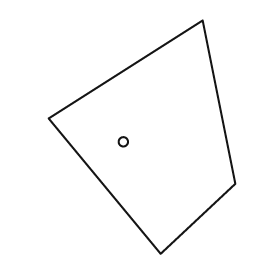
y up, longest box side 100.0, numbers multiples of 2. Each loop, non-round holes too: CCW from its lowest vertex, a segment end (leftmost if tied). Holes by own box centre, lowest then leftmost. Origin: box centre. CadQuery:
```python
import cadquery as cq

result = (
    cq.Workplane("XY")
    .moveTo(8.0, -50.0)
    .lineTo(40.0, -20.0)
    .lineTo(26.0, 50.0)
    .lineTo(-40.0, 8.0)
    .close()
    .moveTo(-8.0, -2.0)
    .circle(2.0)
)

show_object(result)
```